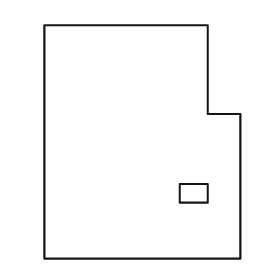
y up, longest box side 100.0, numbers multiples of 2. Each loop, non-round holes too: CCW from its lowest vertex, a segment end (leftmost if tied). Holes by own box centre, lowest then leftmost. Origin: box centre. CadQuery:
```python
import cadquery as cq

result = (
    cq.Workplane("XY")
    .moveTo(-42.0, -50.0)
    .lineTo(42.0, -50.0)
    .lineTo(42.0, 12.0)
    .lineTo(28.0, 12.0)
    .lineTo(28.0, 50.0)
    .lineTo(-42.0, 50.0)
    .close()
    .moveTo(16.0, -26.0)
    .lineTo(28.0, -26.0)
    .lineTo(28.0, -18.0)
    .lineTo(16.0, -18.0)
    .close()
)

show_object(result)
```